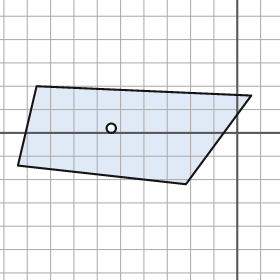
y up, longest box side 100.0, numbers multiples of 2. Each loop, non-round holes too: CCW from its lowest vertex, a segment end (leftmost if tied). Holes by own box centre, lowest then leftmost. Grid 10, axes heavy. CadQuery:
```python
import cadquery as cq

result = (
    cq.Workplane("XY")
    .moveTo(-22.0, -22.0)
    .lineTo(6.0, 16.0)
    .lineTo(-86.0, 20.0)
    .lineTo(-94.0, -14.0)
    .close()
    .moveTo(-54.0, 2.0)
    .circle(2.0)
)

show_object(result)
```